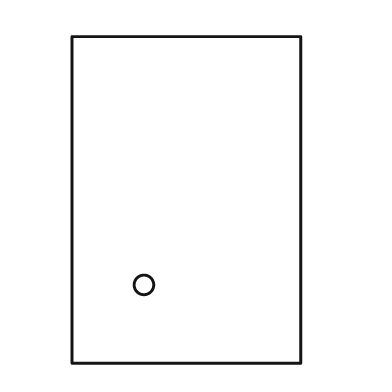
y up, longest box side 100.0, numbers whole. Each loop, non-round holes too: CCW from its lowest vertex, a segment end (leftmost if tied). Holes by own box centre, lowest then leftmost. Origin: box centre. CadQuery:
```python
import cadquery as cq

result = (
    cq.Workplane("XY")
    .moveTo(-35.0, -50.0)
    .lineTo(35.0, -50.0)
    .lineTo(35.0, 50.0)
    .lineTo(-35.0, 50.0)
    .close()
    .moveTo(-13.0, -26.0)
    .circle(3.0)
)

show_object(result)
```